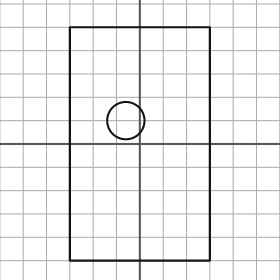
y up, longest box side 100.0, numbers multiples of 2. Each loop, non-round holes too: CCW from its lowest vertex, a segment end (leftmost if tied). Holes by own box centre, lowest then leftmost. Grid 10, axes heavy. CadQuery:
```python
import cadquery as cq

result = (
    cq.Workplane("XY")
    .moveTo(-30.0, -50.0)
    .lineTo(30.0, -50.0)
    .lineTo(30.0, 50.0)
    .lineTo(-30.0, 50.0)
    .close()
    .moveTo(-6.0, 10.0)
    .circle(8.0)
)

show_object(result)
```